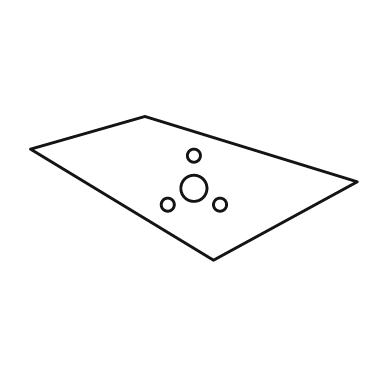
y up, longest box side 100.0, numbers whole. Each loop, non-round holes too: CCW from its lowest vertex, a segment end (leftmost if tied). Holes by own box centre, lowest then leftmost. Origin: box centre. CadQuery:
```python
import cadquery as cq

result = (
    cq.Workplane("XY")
    .moveTo(6.0, -22.0)
    .lineTo(50.0, 2.0)
    .lineTo(-15.0, 22.0)
    .lineTo(-50.0, 12.0)
    .close()
    .moveTo(-8.0, -5.0)
    .circle(2.0)
    .moveTo(8.0, -5.0)
    .circle(2.0)
    .moveTo(0.0, 0.0)
    .circle(4.0)
    .moveTo(0.0, 10.0)
    .circle(2.0)
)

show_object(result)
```